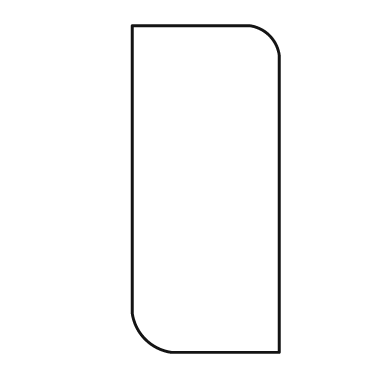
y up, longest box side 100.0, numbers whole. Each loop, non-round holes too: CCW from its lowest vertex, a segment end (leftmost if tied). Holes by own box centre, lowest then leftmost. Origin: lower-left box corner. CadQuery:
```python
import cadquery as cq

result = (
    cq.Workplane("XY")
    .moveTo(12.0, 0.0)
    .lineTo(45.0, 0.0)
    .lineTo(45.0, 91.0)
    .threePointArc((42.0, 97.0), (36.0, 100.0))
    .lineTo(0.0, 100.0)
    .lineTo(0.0, 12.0)
    .threePointArc((4.0, 4.0), (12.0, 0.0))
    .close()
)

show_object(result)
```